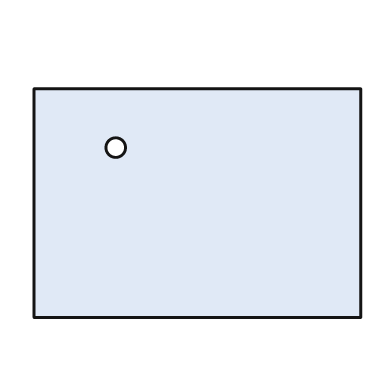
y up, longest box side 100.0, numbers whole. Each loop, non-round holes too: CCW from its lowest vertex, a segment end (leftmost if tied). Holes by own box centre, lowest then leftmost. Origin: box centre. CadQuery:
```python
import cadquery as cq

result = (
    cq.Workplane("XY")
    .moveTo(-50.0, -35.0)
    .lineTo(50.0, -35.0)
    .lineTo(50.0, 35.0)
    .lineTo(-50.0, 35.0)
    .close()
    .moveTo(-25.0, 17.0)
    .circle(3.0)
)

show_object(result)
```